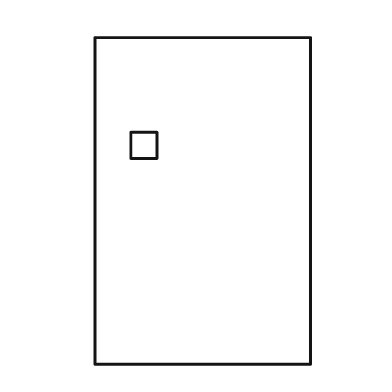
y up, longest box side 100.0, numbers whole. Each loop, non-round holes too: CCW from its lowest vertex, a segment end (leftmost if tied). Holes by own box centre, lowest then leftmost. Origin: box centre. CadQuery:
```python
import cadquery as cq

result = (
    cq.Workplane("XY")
    .moveTo(-33.0, -50.0)
    .lineTo(33.0, -50.0)
    .lineTo(33.0, 50.0)
    .lineTo(-33.0, 50.0)
    .close()
    .moveTo(-22.0, 13.0)
    .lineTo(-14.0, 13.0)
    .lineTo(-14.0, 21.0)
    .lineTo(-22.0, 21.0)
    .close()
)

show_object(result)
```